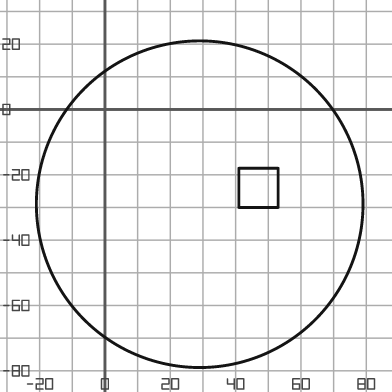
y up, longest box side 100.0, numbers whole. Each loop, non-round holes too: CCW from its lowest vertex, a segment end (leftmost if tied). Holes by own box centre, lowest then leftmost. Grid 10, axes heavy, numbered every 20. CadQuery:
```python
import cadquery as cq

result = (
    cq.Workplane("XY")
    .moveTo(29.0, -29.0)
    .circle(50.0)
    .moveTo(41.0, -30.0)
    .lineTo(53.0, -30.0)
    .lineTo(53.0, -18.0)
    .lineTo(41.0, -18.0)
    .close()
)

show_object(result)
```